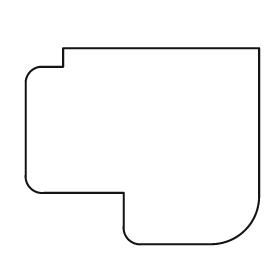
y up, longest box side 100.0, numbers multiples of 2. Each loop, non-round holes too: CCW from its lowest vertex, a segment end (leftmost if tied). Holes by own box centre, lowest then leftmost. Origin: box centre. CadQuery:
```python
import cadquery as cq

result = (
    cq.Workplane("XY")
    .moveTo(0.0, -42.0)
    .lineTo(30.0, -42.0)
    .threePointArc((44.0, -36.0), (50.0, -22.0))
    .lineTo(50.0, 42.0)
    .lineTo(-34.0, 42.0)
    .lineTo(-34.0, 34.0)
    .lineTo(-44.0, 34.0)
    .threePointArc((-48.0, 32.0), (-50.0, 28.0))
    .lineTo(-50.0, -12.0)
    .threePointArc((-48.0, -18.0), (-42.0, -20.0))
    .lineTo(-8.0, -20.0)
    .lineTo(-8.0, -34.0)
    .threePointArc((-6.0, -40.0), (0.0, -42.0))
    .close()
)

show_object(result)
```